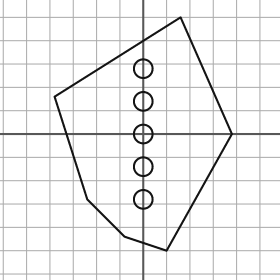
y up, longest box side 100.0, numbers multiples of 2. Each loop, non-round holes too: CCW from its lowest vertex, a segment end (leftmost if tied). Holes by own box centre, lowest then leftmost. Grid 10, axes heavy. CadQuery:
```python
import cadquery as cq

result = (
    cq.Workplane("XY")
    .moveTo(10.0, -50.0)
    .lineTo(38.0, 0.0)
    .lineTo(16.0, 50.0)
    .lineTo(-38.0, 16.0)
    .lineTo(-24.0, -28.0)
    .lineTo(-8.0, -44.0)
    .close()
    .moveTo(0.0, -28.0)
    .circle(4.0)
    .moveTo(0.0, -14.0)
    .circle(4.0)
    .moveTo(0.0, 0.0)
    .circle(4.0)
    .moveTo(0.0, 14.0)
    .circle(4.0)
    .moveTo(0.0, 28.0)
    .circle(4.0)
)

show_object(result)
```